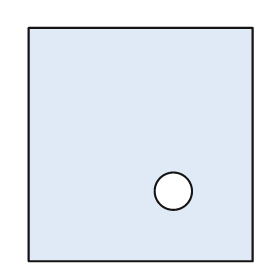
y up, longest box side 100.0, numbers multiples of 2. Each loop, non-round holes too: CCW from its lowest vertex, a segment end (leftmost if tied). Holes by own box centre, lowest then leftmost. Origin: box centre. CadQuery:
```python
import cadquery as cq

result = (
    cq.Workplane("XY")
    .moveTo(-48.0, -50.0)
    .lineTo(48.0, -50.0)
    .lineTo(48.0, 50.0)
    .lineTo(-48.0, 50.0)
    .close()
    .moveTo(14.0, -20.0)
    .circle(8.0)
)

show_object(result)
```